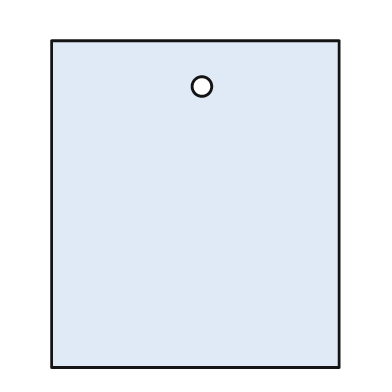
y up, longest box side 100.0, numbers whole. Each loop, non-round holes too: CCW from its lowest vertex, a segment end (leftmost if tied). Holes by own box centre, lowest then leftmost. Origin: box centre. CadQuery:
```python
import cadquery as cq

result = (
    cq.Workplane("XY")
    .moveTo(-44.0, -50.0)
    .lineTo(44.0, -50.0)
    .lineTo(44.0, 50.0)
    .lineTo(-44.0, 50.0)
    .close()
    .moveTo(2.0, 36.0)
    .circle(3.0)
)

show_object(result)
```